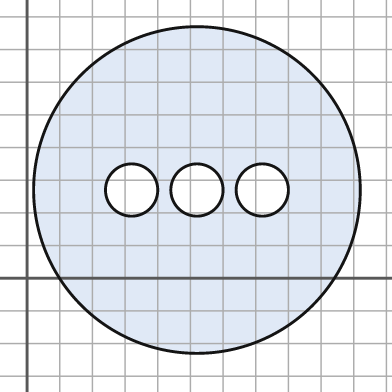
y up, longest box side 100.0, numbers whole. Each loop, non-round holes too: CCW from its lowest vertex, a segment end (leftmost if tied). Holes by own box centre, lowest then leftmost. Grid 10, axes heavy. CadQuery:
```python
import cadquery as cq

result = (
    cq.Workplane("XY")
    .moveTo(52.0, 27.0)
    .circle(50.0)
    .moveTo(32.0, 27.0)
    .circle(8.0)
    .moveTo(52.0, 27.0)
    .circle(8.0)
    .moveTo(72.0, 27.0)
    .circle(8.0)
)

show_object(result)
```